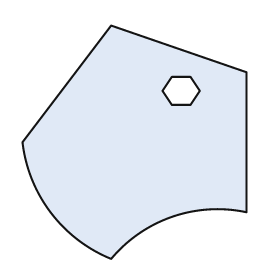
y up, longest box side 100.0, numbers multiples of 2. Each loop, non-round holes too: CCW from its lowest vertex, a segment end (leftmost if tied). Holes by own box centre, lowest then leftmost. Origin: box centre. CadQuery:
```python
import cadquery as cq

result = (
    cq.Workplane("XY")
    .moveTo(-10.0, -50.0)
    .threePointArc((16.0, -32.0), (48.0, -30.0))
    .lineTo(48.0, 30.0)
    .lineTo(-10.0, 50.0)
    .lineTo(-48.0, 0.0)
    .threePointArc((-36.0, -30.0), (-10.0, -50.0))
    .close()
    .moveTo(16.0, 16.0)
    .lineTo(24.0, 16.0)
    .lineTo(28.0, 22.0)
    .lineTo(24.0, 28.0)
    .lineTo(16.0, 28.0)
    .lineTo(12.0, 22.0)
    .close()
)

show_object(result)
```